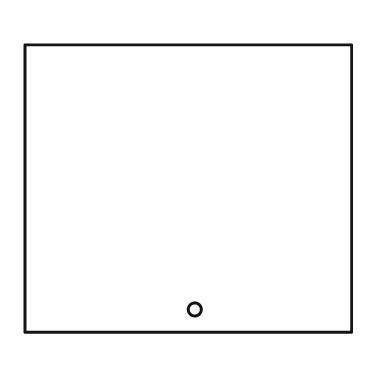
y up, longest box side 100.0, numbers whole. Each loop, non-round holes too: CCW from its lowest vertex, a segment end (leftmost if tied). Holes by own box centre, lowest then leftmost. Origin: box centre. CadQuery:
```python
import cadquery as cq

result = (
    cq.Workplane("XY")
    .moveTo(-50.0, -44.0)
    .lineTo(50.0, -44.0)
    .lineTo(50.0, 44.0)
    .lineTo(-50.0, 44.0)
    .close()
    .moveTo(2.0, -37.0)
    .circle(2.0)
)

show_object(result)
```